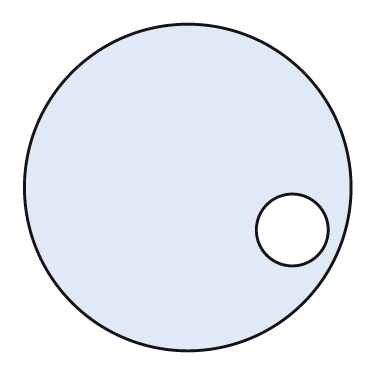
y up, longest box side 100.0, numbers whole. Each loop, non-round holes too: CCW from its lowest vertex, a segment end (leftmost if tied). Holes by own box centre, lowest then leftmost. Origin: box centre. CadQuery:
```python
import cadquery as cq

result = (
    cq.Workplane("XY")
    .moveTo(0.0, 0.0)
    .circle(50.0)
    .moveTo(32.0, -13.0)
    .circle(11.0)
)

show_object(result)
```